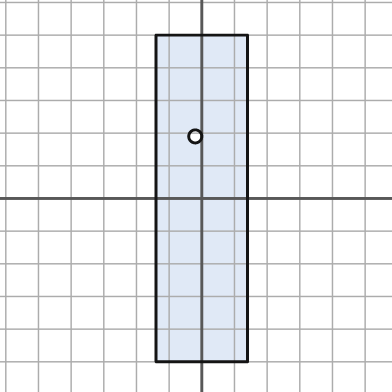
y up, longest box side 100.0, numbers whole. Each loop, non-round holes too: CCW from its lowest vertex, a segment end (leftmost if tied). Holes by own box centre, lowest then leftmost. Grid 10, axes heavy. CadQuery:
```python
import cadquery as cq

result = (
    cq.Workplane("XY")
    .moveTo(-14.0, -50.0)
    .lineTo(14.0, -50.0)
    .lineTo(14.0, 50.0)
    .lineTo(-14.0, 50.0)
    .close()
    .moveTo(-2.0, 19.0)
    .circle(2.0)
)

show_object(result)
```